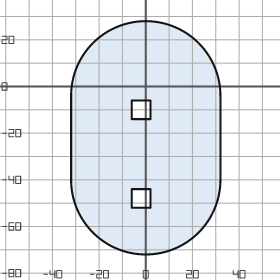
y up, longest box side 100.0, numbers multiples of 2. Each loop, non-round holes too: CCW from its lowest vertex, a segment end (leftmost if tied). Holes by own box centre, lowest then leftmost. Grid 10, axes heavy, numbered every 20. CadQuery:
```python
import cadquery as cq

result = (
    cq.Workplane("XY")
    .moveTo(-32.0, -40.0)
    .threePointArc((0.0, -72.0), (32.0, -40.0))
    .lineTo(32.0, -4.0)
    .threePointArc((0.0, 28.0), (-32.0, -4.0))
    .close()
    .moveTo(-6.0, -52.0)
    .lineTo(2.0, -52.0)
    .lineTo(2.0, -44.0)
    .lineTo(-6.0, -44.0)
    .close()
    .moveTo(-6.0, -14.0)
    .lineTo(2.0, -14.0)
    .lineTo(2.0, -6.0)
    .lineTo(-6.0, -6.0)
    .close()
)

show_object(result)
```